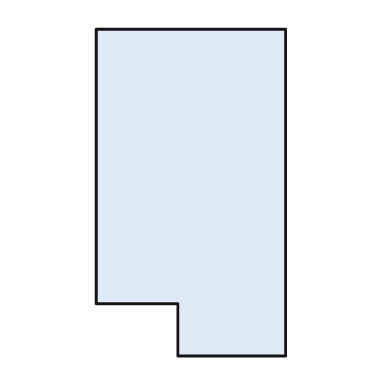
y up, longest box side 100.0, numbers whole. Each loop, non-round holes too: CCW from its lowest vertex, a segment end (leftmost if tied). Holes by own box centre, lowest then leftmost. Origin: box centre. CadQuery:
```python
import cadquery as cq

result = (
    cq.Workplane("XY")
    .moveTo(-4.0, -50.0)
    .lineTo(29.0, -50.0)
    .lineTo(29.0, 50.0)
    .lineTo(-29.0, 50.0)
    .lineTo(-29.0, -34.0)
    .lineTo(-4.0, -34.0)
    .close()
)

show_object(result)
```